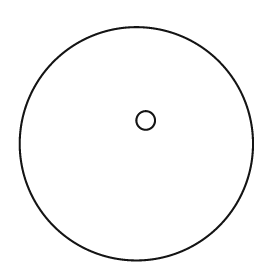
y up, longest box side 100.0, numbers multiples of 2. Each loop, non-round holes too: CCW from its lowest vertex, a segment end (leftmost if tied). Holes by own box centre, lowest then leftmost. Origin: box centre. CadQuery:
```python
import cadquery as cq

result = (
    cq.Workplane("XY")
    .moveTo(0.0, 0.0)
    .circle(50.0)
    .moveTo(4.0, 10.0)
    .circle(4.0)
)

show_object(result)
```